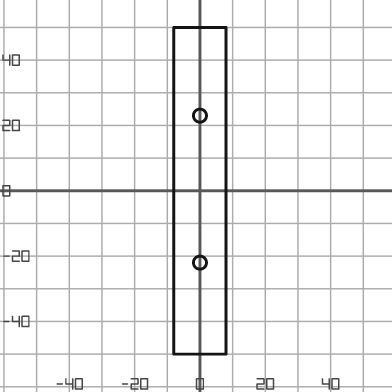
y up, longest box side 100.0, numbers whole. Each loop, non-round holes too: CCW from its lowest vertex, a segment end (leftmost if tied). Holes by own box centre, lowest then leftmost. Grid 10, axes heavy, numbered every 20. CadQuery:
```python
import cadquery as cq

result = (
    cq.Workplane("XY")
    .moveTo(-8.0, -50.0)
    .lineTo(8.0, -50.0)
    .lineTo(8.0, 50.0)
    .lineTo(-8.0, 50.0)
    .close()
    .moveTo(0.0, -22.0)
    .circle(2.0)
    .moveTo(0.0, 23.0)
    .circle(2.0)
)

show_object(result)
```